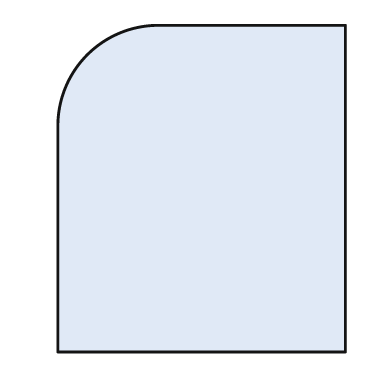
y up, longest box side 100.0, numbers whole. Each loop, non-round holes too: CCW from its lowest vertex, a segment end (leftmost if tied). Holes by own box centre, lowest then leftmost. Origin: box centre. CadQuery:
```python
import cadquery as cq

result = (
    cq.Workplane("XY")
    .moveTo(-44.0, -50.0)
    .lineTo(44.0, -50.0)
    .lineTo(44.0, 50.0)
    .lineTo(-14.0, 50.0)
    .threePointArc((-35.0, 41.0), (-44.0, 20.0))
    .close()
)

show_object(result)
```